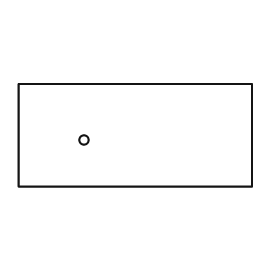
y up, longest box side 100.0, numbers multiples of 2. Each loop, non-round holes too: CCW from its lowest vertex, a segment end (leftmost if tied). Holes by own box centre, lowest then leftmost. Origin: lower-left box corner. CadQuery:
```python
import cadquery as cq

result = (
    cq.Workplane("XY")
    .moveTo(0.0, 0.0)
    .lineTo(100.0, 0.0)
    .lineTo(100.0, 44.0)
    .lineTo(0.0, 44.0)
    .close()
    .moveTo(28.0, 20.0)
    .circle(2.0)
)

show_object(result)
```